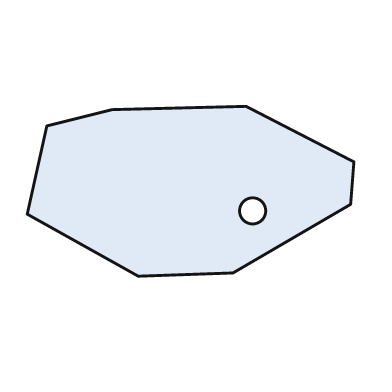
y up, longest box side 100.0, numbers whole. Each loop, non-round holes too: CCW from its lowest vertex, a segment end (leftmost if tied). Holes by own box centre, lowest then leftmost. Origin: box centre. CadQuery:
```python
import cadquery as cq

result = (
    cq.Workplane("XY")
    .moveTo(-16.0, -26.0)
    .lineTo(13.0, -25.0)
    .lineTo(49.0, -4.0)
    .lineTo(50.0, 9.0)
    .lineTo(17.0, 26.0)
    .lineTo(-24.0, 25.0)
    .lineTo(-44.0, 20.0)
    .lineTo(-50.0, -7.0)
    .close()
    .moveTo(19.0, -6.0)
    .circle(4.0)
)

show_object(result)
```